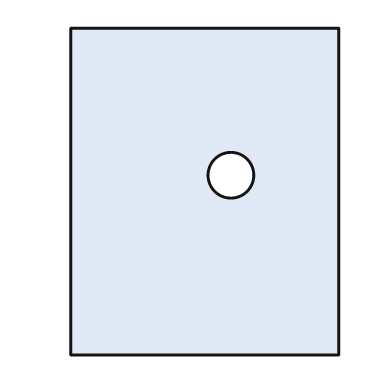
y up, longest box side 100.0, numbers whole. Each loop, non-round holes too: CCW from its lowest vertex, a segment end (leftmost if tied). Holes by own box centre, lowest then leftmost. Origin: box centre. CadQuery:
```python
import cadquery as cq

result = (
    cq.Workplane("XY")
    .moveTo(-41.0, -50.0)
    .lineTo(41.0, -50.0)
    .lineTo(41.0, 50.0)
    .lineTo(-41.0, 50.0)
    .close()
    .moveTo(8.0, 5.0)
    .circle(7.0)
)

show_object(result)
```